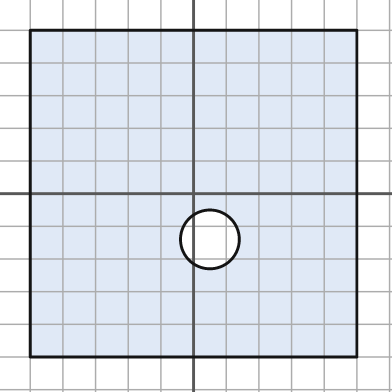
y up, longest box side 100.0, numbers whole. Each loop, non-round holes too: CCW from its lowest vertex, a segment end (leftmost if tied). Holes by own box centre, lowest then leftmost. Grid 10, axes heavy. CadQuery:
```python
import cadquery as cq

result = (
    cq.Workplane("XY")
    .moveTo(-50.0, -50.0)
    .lineTo(50.0, -50.0)
    .lineTo(50.0, 50.0)
    .lineTo(-50.0, 50.0)
    .close()
    .moveTo(5.0, -14.0)
    .circle(9.0)
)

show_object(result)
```